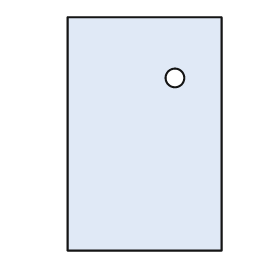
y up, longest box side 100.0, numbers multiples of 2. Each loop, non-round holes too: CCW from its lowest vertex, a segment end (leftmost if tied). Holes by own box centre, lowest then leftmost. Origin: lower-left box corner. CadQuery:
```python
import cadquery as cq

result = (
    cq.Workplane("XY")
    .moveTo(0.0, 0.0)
    .lineTo(66.0, 0.0)
    .lineTo(66.0, 100.0)
    .lineTo(0.0, 100.0)
    .close()
    .moveTo(46.0, 74.0)
    .circle(4.0)
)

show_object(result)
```